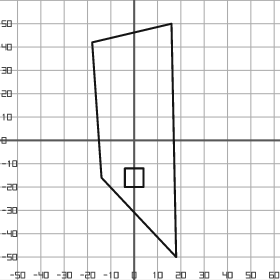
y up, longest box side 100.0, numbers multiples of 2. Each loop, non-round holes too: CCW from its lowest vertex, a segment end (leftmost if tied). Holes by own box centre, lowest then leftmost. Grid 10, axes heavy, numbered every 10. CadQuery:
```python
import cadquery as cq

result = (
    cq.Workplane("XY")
    .moveTo(18.0, -50.0)
    .lineTo(16.0, 50.0)
    .lineTo(-18.0, 42.0)
    .lineTo(-14.0, -16.0)
    .close()
    .moveTo(-4.0, -20.0)
    .lineTo(4.0, -20.0)
    .lineTo(4.0, -12.0)
    .lineTo(-4.0, -12.0)
    .close()
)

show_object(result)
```